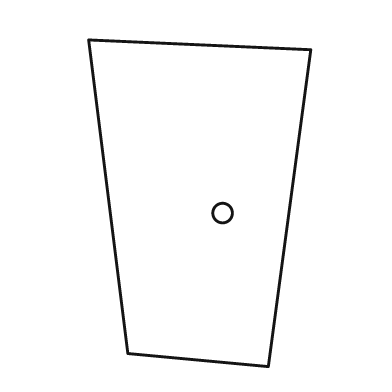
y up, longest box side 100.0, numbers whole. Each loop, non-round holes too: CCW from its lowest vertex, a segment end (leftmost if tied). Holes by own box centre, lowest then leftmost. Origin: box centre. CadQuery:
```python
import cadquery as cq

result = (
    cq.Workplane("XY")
    .moveTo(21.0, -50.0)
    .lineTo(34.0, 47.0)
    .lineTo(-34.0, 50.0)
    .lineTo(-22.0, -46.0)
    .close()
    .moveTo(7.0, -3.0)
    .circle(3.0)
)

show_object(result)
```